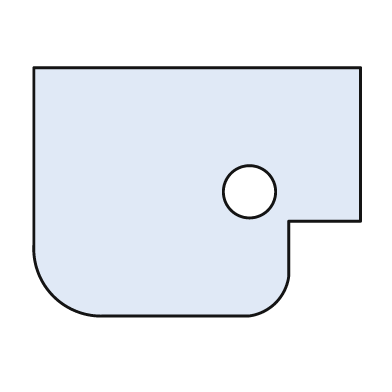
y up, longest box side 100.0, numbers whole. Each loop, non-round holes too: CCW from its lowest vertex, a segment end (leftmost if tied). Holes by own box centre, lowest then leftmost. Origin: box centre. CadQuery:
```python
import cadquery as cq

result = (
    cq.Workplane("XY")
    .moveTo(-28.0, -38.0)
    .lineTo(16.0, -38.0)
    .threePointArc((24.0, -34.0), (28.0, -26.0))
    .lineTo(28.0, -9.0)
    .lineTo(50.0, -9.0)
    .lineTo(50.0, 38.0)
    .lineTo(-50.0, 38.0)
    .lineTo(-50.0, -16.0)
    .threePointArc((-44.0, -32.0), (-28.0, -38.0))
    .close()
    .moveTo(16.0, 0.0)
    .circle(8.0)
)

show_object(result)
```